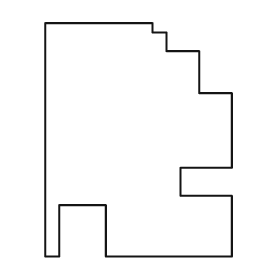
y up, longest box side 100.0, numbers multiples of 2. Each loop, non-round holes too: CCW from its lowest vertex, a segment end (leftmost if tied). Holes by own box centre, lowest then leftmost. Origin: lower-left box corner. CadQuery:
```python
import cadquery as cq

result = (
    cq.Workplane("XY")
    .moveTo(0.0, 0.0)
    .lineTo(6.0, 0.0)
    .lineTo(6.0, 22.0)
    .lineTo(26.0, 22.0)
    .lineTo(26.0, 0.0)
    .lineTo(80.0, 0.0)
    .lineTo(80.0, 26.0)
    .lineTo(58.0, 26.0)
    .lineTo(58.0, 38.0)
    .lineTo(80.0, 38.0)
    .lineTo(80.0, 70.0)
    .lineTo(66.0, 70.0)
    .lineTo(66.0, 88.0)
    .lineTo(52.0, 88.0)
    .lineTo(52.0, 96.0)
    .lineTo(46.0, 96.0)
    .lineTo(46.0, 100.0)
    .lineTo(0.0, 100.0)
    .close()
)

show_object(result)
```